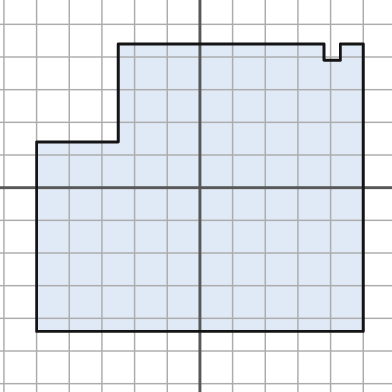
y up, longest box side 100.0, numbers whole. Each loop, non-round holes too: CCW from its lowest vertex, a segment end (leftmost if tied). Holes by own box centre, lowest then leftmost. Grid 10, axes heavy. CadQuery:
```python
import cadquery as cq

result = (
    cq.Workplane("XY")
    .moveTo(-50.0, -44.0)
    .lineTo(50.0, -44.0)
    .lineTo(50.0, 44.0)
    .lineTo(43.0, 44.0)
    .lineTo(43.0, 39.0)
    .lineTo(38.0, 39.0)
    .lineTo(38.0, 44.0)
    .lineTo(-25.0, 44.0)
    .lineTo(-25.0, 14.0)
    .lineTo(-50.0, 14.0)
    .close()
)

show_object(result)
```